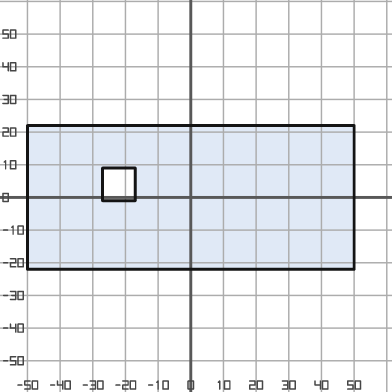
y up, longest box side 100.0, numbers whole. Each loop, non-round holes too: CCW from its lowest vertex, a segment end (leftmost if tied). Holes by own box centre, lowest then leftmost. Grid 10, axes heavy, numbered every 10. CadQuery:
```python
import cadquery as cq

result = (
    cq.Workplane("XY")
    .moveTo(-50.0, -22.0)
    .lineTo(50.0, -22.0)
    .lineTo(50.0, 22.0)
    .lineTo(-50.0, 22.0)
    .close()
    .moveTo(-27.0, -1.0)
    .lineTo(-17.0, -1.0)
    .lineTo(-17.0, 9.0)
    .lineTo(-27.0, 9.0)
    .close()
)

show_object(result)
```